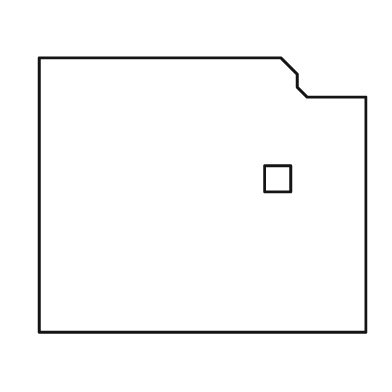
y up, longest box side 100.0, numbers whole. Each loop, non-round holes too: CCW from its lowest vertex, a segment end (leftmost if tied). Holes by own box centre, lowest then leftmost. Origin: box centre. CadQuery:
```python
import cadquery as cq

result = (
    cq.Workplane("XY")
    .moveTo(-50.0, -42.0)
    .lineTo(50.0, -42.0)
    .lineTo(50.0, 30.0)
    .lineTo(32.0, 30.0)
    .lineTo(29.0, 33.0)
    .lineTo(29.0, 37.0)
    .lineTo(24.0, 42.0)
    .lineTo(-50.0, 42.0)
    .close()
    .moveTo(19.0, 1.0)
    .lineTo(27.0, 1.0)
    .lineTo(27.0, 9.0)
    .lineTo(19.0, 9.0)
    .close()
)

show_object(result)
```